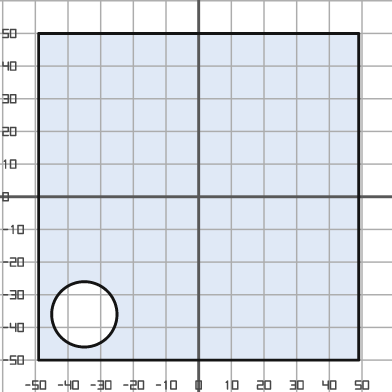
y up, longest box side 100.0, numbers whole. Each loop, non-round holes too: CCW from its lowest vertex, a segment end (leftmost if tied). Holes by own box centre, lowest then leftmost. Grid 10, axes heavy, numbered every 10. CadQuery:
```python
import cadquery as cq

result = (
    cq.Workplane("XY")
    .moveTo(-49.0, -50.0)
    .lineTo(49.0, -50.0)
    .lineTo(49.0, 50.0)
    .lineTo(-49.0, 50.0)
    .close()
    .moveTo(-35.0, -36.0)
    .circle(10.0)
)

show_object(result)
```